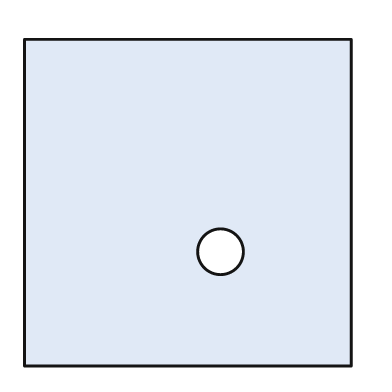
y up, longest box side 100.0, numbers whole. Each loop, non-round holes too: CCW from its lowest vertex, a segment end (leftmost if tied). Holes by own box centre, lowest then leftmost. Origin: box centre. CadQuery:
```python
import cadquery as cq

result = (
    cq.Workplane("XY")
    .moveTo(-50.0, -50.0)
    .lineTo(50.0, -50.0)
    .lineTo(50.0, 50.0)
    .lineTo(-50.0, 50.0)
    .close()
    .moveTo(10.0, -15.0)
    .circle(7.0)
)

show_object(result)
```